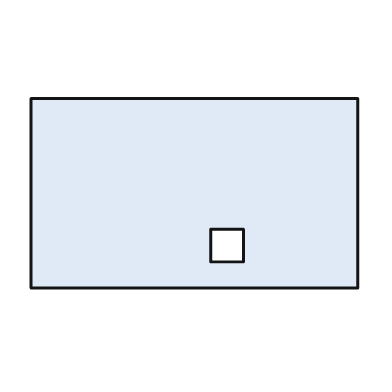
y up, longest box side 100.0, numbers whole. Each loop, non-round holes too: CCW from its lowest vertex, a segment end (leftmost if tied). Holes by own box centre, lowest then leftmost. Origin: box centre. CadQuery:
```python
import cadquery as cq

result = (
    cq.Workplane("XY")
    .moveTo(-50.0, -29.0)
    .lineTo(50.0, -29.0)
    .lineTo(50.0, 29.0)
    .lineTo(-50.0, 29.0)
    .close()
    .moveTo(5.0, -21.0)
    .lineTo(15.0, -21.0)
    .lineTo(15.0, -11.0)
    .lineTo(5.0, -11.0)
    .close()
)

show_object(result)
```